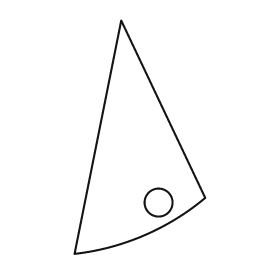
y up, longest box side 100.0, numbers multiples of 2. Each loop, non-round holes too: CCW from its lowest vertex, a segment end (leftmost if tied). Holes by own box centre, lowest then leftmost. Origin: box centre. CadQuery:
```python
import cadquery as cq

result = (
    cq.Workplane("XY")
    .moveTo(-28.0, -50.0)
    .threePointArc((2.0, -42.0), (28.0, -26.0))
    .lineTo(-8.0, 50.0)
    .close()
    .moveTo(8.0, -28.0)
    .circle(6.0)
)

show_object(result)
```